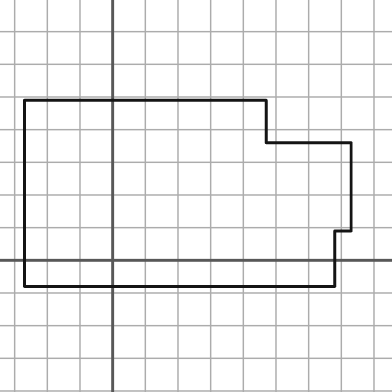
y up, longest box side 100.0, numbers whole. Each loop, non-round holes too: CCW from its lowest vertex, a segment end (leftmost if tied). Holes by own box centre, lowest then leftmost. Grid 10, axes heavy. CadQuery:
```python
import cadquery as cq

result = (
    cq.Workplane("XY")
    .moveTo(-27.0, -8.0)
    .lineTo(68.0, -8.0)
    .lineTo(68.0, 9.0)
    .lineTo(73.0, 9.0)
    .lineTo(73.0, 36.0)
    .lineTo(47.0, 36.0)
    .lineTo(47.0, 49.0)
    .lineTo(-27.0, 49.0)
    .close()
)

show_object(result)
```